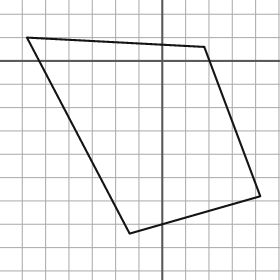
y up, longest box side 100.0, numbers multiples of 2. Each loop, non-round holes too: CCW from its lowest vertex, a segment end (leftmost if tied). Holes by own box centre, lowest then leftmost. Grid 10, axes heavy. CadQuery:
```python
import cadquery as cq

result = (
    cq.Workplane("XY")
    .moveTo(-14.0, -74.0)
    .lineTo(42.0, -58.0)
    .lineTo(18.0, 6.0)
    .lineTo(-58.0, 10.0)
    .close()
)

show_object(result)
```